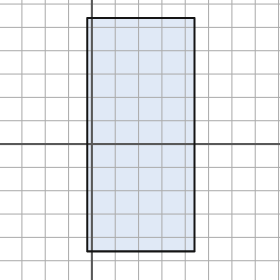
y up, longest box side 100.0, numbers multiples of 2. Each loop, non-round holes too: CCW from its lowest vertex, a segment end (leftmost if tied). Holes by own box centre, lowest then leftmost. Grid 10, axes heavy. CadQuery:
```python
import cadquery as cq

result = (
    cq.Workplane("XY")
    .moveTo(-2.0, -46.0)
    .lineTo(44.0, -46.0)
    .lineTo(44.0, 54.0)
    .lineTo(-2.0, 54.0)
    .close()
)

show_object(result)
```